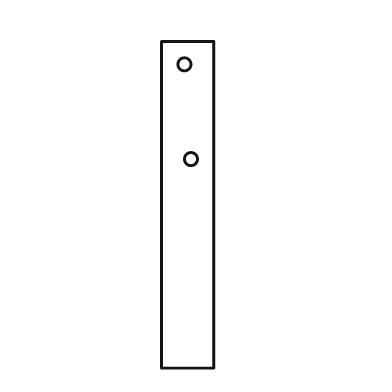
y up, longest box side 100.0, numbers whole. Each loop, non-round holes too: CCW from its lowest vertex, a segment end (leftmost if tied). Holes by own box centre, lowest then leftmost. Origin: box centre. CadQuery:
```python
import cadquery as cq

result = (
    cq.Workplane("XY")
    .moveTo(-8.0, -50.0)
    .lineTo(8.0, -50.0)
    .lineTo(8.0, 50.0)
    .lineTo(-8.0, 50.0)
    .close()
    .moveTo(1.0, 14.0)
    .circle(2.0)
    .moveTo(-1.0, 43.0)
    .circle(2.0)
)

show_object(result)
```